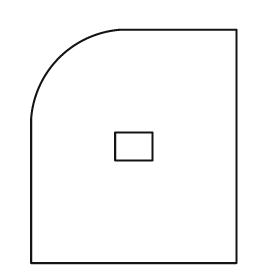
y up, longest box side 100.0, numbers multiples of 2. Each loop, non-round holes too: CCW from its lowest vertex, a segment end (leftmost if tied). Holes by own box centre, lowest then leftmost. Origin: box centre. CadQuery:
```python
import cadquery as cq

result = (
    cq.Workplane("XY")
    .moveTo(-44.0, -50.0)
    .lineTo(44.0, -50.0)
    .lineTo(44.0, 50.0)
    .lineTo(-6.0, 50.0)
    .threePointArc((-32.0, 38.0), (-44.0, 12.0))
    .close()
    .moveTo(-8.0, -6.0)
    .lineTo(8.0, -6.0)
    .lineTo(8.0, 6.0)
    .lineTo(-8.0, 6.0)
    .close()
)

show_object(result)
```